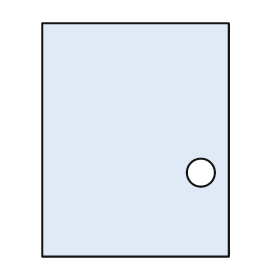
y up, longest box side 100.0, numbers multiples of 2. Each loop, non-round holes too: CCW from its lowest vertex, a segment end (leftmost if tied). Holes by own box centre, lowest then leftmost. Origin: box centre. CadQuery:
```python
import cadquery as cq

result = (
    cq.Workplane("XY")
    .moveTo(-40.0, -50.0)
    .lineTo(40.0, -50.0)
    .lineTo(40.0, 50.0)
    .lineTo(-40.0, 50.0)
    .close()
    .moveTo(28.0, -14.0)
    .circle(6.0)
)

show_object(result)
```